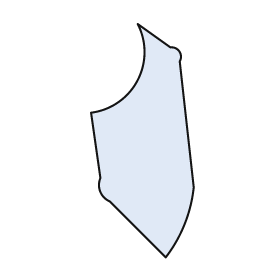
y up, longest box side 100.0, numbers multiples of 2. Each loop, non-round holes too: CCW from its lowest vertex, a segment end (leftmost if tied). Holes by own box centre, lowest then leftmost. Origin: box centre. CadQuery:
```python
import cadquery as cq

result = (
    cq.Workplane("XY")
    .moveTo(10.0, -50.0)
    .threePointArc((18.0, -36.0), (22.0, -20.0))
    .lineTo(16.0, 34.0)
    .threePointArc((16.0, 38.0), (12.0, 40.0))
    .lineTo(-2.0, 50.0)
    .threePointArc((-2.0, 26.0), (-22.0, 12.0))
    .lineTo(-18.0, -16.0)
    .threePointArc((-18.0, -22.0), (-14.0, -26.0))
    .close()
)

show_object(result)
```